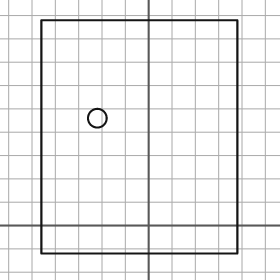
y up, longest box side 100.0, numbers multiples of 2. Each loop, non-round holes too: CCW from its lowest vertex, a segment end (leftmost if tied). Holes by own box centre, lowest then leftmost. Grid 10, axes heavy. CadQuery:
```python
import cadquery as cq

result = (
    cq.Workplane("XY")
    .moveTo(-46.0, -12.0)
    .lineTo(38.0, -12.0)
    .lineTo(38.0, 88.0)
    .lineTo(-46.0, 88.0)
    .close()
    .moveTo(-22.0, 46.0)
    .circle(4.0)
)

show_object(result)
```